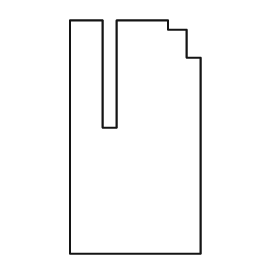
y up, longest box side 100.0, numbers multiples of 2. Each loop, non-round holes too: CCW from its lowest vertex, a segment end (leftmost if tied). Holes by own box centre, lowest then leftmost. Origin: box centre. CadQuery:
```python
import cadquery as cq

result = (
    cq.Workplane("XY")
    .moveTo(-28.0, -50.0)
    .lineTo(28.0, -50.0)
    .lineTo(28.0, 34.0)
    .lineTo(22.0, 34.0)
    .lineTo(22.0, 46.0)
    .lineTo(14.0, 46.0)
    .lineTo(14.0, 50.0)
    .lineTo(-8.0, 50.0)
    .lineTo(-8.0, 4.0)
    .lineTo(-14.0, 4.0)
    .lineTo(-14.0, 50.0)
    .lineTo(-28.0, 50.0)
    .close()
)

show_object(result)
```